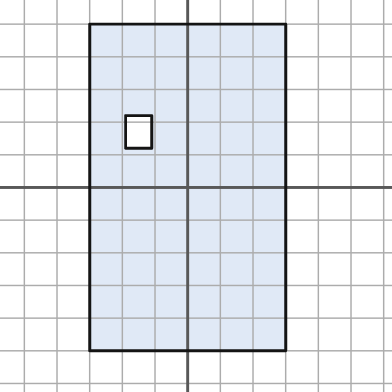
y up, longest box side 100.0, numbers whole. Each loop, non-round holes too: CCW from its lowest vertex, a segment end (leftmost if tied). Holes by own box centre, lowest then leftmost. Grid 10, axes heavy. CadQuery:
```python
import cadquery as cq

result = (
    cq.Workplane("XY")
    .moveTo(-30.0, -50.0)
    .lineTo(30.0, -50.0)
    .lineTo(30.0, 50.0)
    .lineTo(-30.0, 50.0)
    .close()
    .moveTo(-19.0, 12.0)
    .lineTo(-11.0, 12.0)
    .lineTo(-11.0, 22.0)
    .lineTo(-19.0, 22.0)
    .close()
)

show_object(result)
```